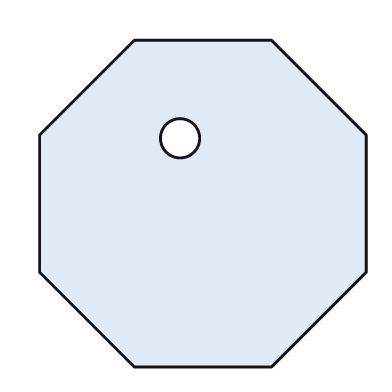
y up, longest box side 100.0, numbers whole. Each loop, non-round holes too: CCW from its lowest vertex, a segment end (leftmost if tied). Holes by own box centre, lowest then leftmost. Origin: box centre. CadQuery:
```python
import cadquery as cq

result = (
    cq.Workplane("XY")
    .moveTo(-21.0, -50.0)
    .lineTo(21.0, -50.0)
    .lineTo(50.0, -21.0)
    .lineTo(50.0, 21.0)
    .lineTo(21.0, 50.0)
    .lineTo(-21.0, 50.0)
    .lineTo(-50.0, 21.0)
    .lineTo(-50.0, -21.0)
    .close()
    .moveTo(-7.0, 20.0)
    .circle(6.0)
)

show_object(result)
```